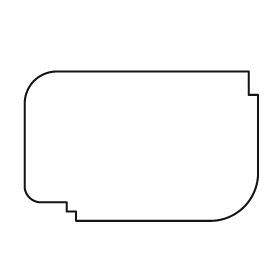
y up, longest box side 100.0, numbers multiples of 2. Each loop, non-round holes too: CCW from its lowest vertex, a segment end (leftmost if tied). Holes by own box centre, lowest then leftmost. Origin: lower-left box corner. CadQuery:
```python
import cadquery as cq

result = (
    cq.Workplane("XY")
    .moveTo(22.0, 0.0)
    .lineTo(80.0, 0.0)
    .threePointArc((94.0, 6.0), (100.0, 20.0))
    .lineTo(100.0, 54.0)
    .lineTo(96.0, 54.0)
    .lineTo(96.0, 64.0)
    .lineTo(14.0, 64.0)
    .threePointArc((4.0, 60.0), (0.0, 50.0))
    .lineTo(0.0, 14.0)
    .threePointArc((2.0, 10.0), (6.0, 8.0))
    .lineTo(18.0, 8.0)
    .lineTo(18.0, 4.0)
    .lineTo(22.0, 4.0)
    .close()
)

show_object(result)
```